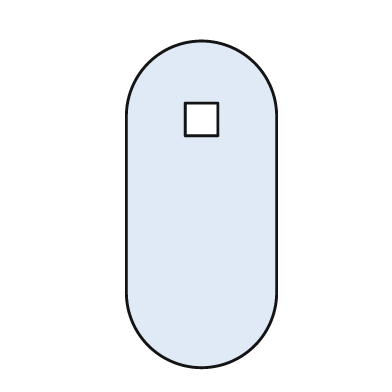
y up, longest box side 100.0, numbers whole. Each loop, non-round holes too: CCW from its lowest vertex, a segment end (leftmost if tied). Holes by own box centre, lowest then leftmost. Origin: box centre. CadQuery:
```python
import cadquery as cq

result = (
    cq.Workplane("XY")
    .moveTo(-23.0, -27.0)
    .threePointArc((0.0, -50.0), (23.0, -27.0))
    .lineTo(23.0, 27.0)
    .threePointArc((0.0, 50.0), (-23.0, 27.0))
    .close()
    .moveTo(-5.0, 21.0)
    .lineTo(5.0, 21.0)
    .lineTo(5.0, 31.0)
    .lineTo(-5.0, 31.0)
    .close()
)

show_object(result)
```